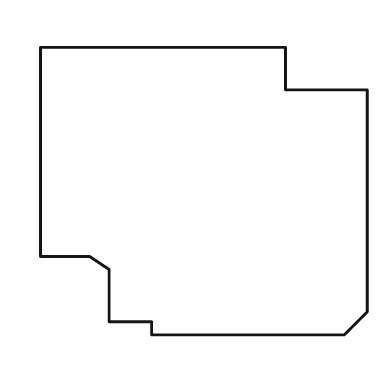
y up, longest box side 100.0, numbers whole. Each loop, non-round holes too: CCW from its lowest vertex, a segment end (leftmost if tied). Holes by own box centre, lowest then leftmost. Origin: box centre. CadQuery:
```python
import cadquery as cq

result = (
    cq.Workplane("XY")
    .moveTo(-16.0, -44.0)
    .lineTo(43.0, -44.0)
    .lineTo(50.0, -37.0)
    .lineTo(50.0, 31.0)
    .lineTo(25.0, 31.0)
    .lineTo(25.0, 44.0)
    .lineTo(-50.0, 44.0)
    .lineTo(-50.0, -20.0)
    .lineTo(-35.0, -20.0)
    .lineTo(-29.0, -24.0)
    .lineTo(-29.0, -40.0)
    .lineTo(-16.0, -40.0)
    .close()
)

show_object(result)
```